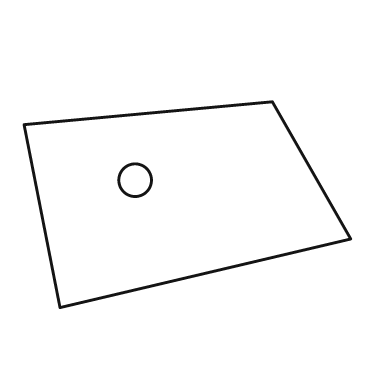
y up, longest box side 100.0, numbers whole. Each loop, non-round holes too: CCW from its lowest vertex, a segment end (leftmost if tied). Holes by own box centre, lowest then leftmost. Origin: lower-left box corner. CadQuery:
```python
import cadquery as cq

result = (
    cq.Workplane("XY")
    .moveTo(11.0, 0.0)
    .lineTo(100.0, 21.0)
    .lineTo(76.0, 63.0)
    .lineTo(0.0, 56.0)
    .close()
    .moveTo(34.0, 39.0)
    .circle(5.0)
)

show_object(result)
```